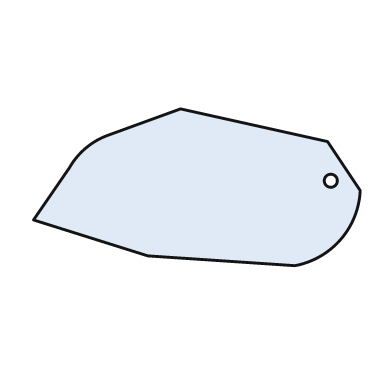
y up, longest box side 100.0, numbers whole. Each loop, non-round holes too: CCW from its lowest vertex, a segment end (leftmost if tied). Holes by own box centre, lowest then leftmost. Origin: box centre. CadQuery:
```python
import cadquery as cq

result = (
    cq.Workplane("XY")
    .moveTo(30.0, -24.0)
    .threePointArc((44.0, -16.0), (50.0, -1.0))
    .lineTo(40.0, 14.0)
    .lineTo(-5.0, 24.0)
    .lineTo(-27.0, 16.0)
    .threePointArc((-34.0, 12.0), (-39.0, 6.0))
    .lineTo(-50.0, -10.0)
    .lineTo(-15.0, -21.0)
    .close()
    .moveTo(41.0, 2.0)
    .circle(2.0)
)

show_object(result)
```